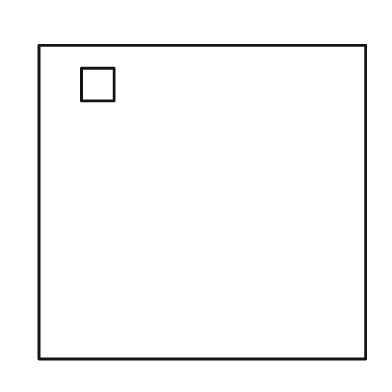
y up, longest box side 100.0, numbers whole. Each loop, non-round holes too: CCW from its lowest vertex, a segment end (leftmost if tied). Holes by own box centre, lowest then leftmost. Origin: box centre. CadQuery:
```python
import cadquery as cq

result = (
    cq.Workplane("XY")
    .moveTo(-50.0, -48.0)
    .lineTo(50.0, -48.0)
    .lineTo(50.0, 48.0)
    .lineTo(-50.0, 48.0)
    .close()
    .moveTo(-37.0, 31.0)
    .lineTo(-27.0, 31.0)
    .lineTo(-27.0, 41.0)
    .lineTo(-37.0, 41.0)
    .close()
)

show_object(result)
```